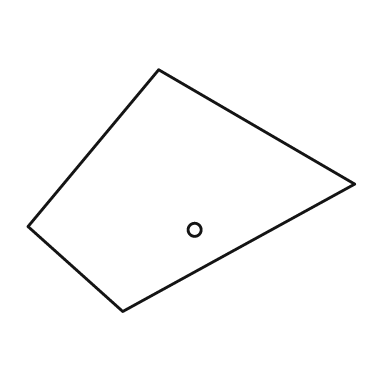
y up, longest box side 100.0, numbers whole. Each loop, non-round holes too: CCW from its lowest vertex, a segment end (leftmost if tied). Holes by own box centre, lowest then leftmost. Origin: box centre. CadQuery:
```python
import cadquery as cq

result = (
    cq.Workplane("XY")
    .moveTo(-21.0, -37.0)
    .lineTo(50.0, 2.0)
    .lineTo(-10.0, 37.0)
    .lineTo(-50.0, -11.0)
    .close()
    .moveTo(1.0, -12.0)
    .circle(2.0)
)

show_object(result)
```